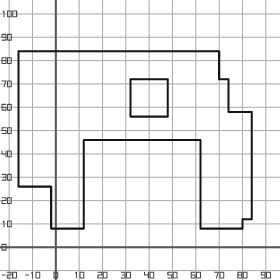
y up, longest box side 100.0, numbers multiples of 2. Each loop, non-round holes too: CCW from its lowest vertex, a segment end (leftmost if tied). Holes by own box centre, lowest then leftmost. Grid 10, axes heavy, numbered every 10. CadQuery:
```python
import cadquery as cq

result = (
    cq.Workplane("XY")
    .moveTo(-2.0, 8.0)
    .lineTo(12.0, 8.0)
    .lineTo(12.0, 46.0)
    .lineTo(62.0, 46.0)
    .lineTo(62.0, 8.0)
    .lineTo(80.0, 8.0)
    .lineTo(80.0, 12.0)
    .lineTo(84.0, 12.0)
    .lineTo(84.0, 58.0)
    .lineTo(74.0, 58.0)
    .lineTo(74.0, 72.0)
    .lineTo(70.0, 72.0)
    .lineTo(70.0, 84.0)
    .lineTo(-16.0, 84.0)
    .lineTo(-16.0, 26.0)
    .lineTo(-2.0, 26.0)
    .close()
    .moveTo(32.0, 56.0)
    .lineTo(48.0, 56.0)
    .lineTo(48.0, 72.0)
    .lineTo(32.0, 72.0)
    .close()
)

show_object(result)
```